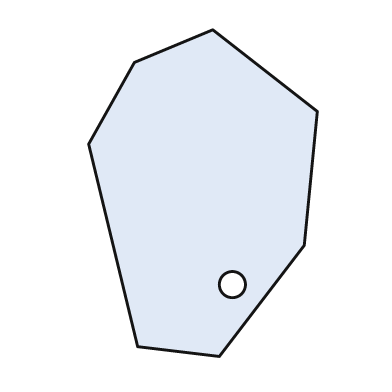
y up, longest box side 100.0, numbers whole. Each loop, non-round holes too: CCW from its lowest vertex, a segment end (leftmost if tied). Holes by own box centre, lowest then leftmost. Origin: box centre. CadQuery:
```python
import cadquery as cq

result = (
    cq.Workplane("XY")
    .moveTo(5.0, -50.0)
    .lineTo(31.0, -16.0)
    .lineTo(35.0, 25.0)
    .lineTo(3.0, 50.0)
    .lineTo(-21.0, 40.0)
    .lineTo(-35.0, 15.0)
    .lineTo(-20.0, -47.0)
    .close()
    .moveTo(9.0, -28.0)
    .circle(4.0)
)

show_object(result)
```